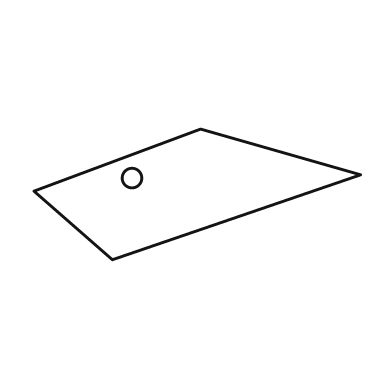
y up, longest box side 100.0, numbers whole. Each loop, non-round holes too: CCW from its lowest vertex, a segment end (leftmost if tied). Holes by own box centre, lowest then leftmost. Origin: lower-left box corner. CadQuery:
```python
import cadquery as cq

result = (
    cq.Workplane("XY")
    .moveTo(24.0, 0.0)
    .lineTo(100.0, 26.0)
    .lineTo(51.0, 40.0)
    .lineTo(0.0, 21.0)
    .close()
    .moveTo(30.0, 25.0)
    .circle(3.0)
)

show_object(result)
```